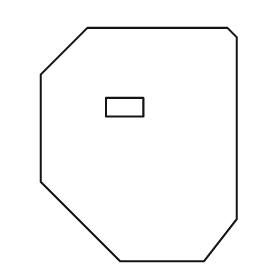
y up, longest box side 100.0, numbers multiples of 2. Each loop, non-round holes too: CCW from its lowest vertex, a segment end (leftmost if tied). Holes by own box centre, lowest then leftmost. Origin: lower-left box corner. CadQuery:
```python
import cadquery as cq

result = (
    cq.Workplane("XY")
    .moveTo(34.0, 0.0)
    .lineTo(70.0, 0.0)
    .lineTo(84.0, 18.0)
    .lineTo(84.0, 96.0)
    .lineTo(80.0, 100.0)
    .lineTo(20.0, 100.0)
    .lineTo(0.0, 80.0)
    .lineTo(0.0, 34.0)
    .close()
    .moveTo(28.0, 62.0)
    .lineTo(44.0, 62.0)
    .lineTo(44.0, 70.0)
    .lineTo(28.0, 70.0)
    .close()
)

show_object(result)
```